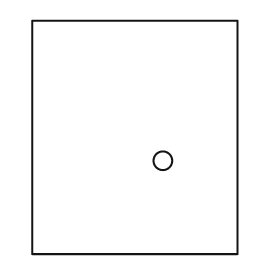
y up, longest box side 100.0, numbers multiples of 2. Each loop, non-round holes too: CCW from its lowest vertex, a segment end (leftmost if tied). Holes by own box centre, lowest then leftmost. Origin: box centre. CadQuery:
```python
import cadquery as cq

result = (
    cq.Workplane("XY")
    .moveTo(-44.0, -50.0)
    .lineTo(44.0, -50.0)
    .lineTo(44.0, 50.0)
    .lineTo(-44.0, 50.0)
    .close()
    .moveTo(12.0, -10.0)
    .circle(4.0)
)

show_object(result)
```